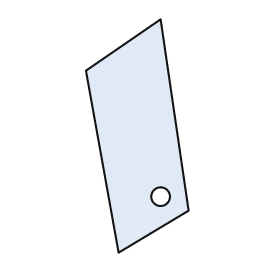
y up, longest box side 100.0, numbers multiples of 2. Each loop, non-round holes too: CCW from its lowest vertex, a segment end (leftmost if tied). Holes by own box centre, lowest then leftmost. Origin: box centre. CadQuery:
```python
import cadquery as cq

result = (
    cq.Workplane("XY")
    .moveTo(-8.0, -50.0)
    .lineTo(22.0, -32.0)
    .lineTo(10.0, 50.0)
    .lineTo(-22.0, 28.0)
    .close()
    .moveTo(10.0, -26.0)
    .circle(4.0)
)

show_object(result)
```